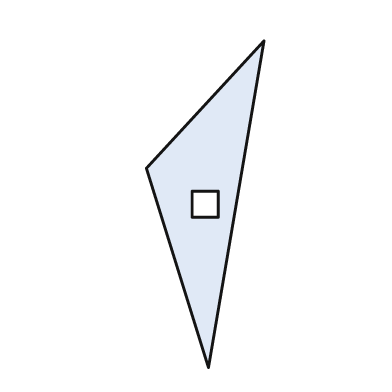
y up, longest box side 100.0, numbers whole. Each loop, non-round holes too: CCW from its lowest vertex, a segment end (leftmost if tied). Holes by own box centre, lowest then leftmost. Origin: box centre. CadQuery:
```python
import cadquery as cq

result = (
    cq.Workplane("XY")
    .moveTo(1.0, -50.0)
    .lineTo(18.0, 50.0)
    .lineTo(-18.0, 11.0)
    .close()
    .moveTo(-4.0, -4.0)
    .lineTo(4.0, -4.0)
    .lineTo(4.0, 4.0)
    .lineTo(-4.0, 4.0)
    .close()
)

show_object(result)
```